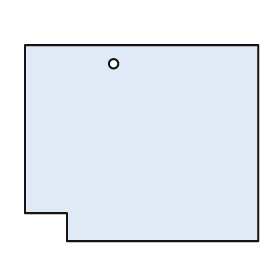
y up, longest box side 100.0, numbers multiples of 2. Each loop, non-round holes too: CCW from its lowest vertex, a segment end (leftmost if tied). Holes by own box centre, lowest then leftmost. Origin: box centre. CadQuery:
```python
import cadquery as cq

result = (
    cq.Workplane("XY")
    .moveTo(-32.0, -42.0)
    .lineTo(50.0, -42.0)
    .lineTo(50.0, 42.0)
    .lineTo(-50.0, 42.0)
    .lineTo(-50.0, -30.0)
    .lineTo(-32.0, -30.0)
    .close()
    .moveTo(-12.0, 34.0)
    .circle(2.0)
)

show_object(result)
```